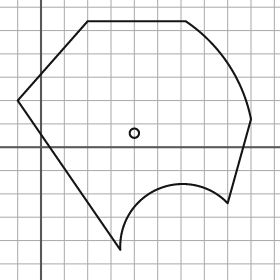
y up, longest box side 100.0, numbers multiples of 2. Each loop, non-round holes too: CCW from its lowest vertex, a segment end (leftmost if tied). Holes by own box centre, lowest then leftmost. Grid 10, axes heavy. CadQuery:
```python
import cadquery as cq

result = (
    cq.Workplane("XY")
    .moveTo(34.0, -44.0)
    .threePointArc((50.0, -18.0), (80.0, -24.0))
    .lineTo(90.0, 12.0)
    .threePointArc((80.0, 36.0), (62.0, 54.0))
    .lineTo(20.0, 54.0)
    .lineTo(-10.0, 20.0)
    .close()
    .moveTo(40.0, 6.0)
    .circle(2.0)
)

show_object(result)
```